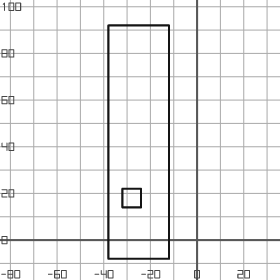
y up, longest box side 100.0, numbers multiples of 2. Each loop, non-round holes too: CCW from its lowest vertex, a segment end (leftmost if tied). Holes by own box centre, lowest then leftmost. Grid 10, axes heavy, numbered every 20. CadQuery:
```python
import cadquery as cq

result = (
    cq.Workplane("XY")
    .moveTo(-38.0, -8.0)
    .lineTo(-12.0, -8.0)
    .lineTo(-12.0, 92.0)
    .lineTo(-38.0, 92.0)
    .close()
    .moveTo(-32.0, 14.0)
    .lineTo(-24.0, 14.0)
    .lineTo(-24.0, 22.0)
    .lineTo(-32.0, 22.0)
    .close()
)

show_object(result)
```